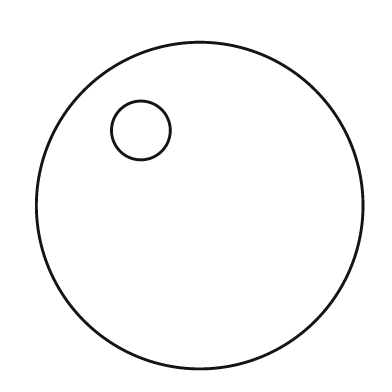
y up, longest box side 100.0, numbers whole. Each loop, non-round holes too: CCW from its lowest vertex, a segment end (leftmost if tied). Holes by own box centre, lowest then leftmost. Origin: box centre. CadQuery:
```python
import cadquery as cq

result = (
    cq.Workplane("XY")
    .moveTo(0.0, 0.0)
    .circle(50.0)
    .moveTo(-18.0, 23.0)
    .circle(9.0)
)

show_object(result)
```